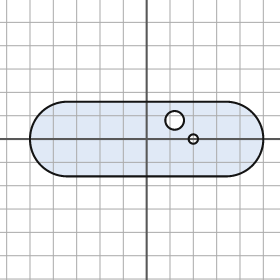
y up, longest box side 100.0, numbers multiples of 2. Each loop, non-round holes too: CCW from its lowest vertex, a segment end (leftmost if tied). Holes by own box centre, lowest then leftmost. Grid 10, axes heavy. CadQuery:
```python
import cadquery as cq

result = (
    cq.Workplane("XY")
    .moveTo(-34.0, -16.0)
    .lineTo(34.0, -16.0)
    .threePointArc((50.0, 0.0), (34.0, 16.0))
    .lineTo(-34.0, 16.0)
    .threePointArc((-50.0, 0.0), (-34.0, -16.0))
    .close()
    .moveTo(20.0, 0.0)
    .circle(2.0)
    .moveTo(12.0, 8.0)
    .circle(4.0)
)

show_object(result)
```